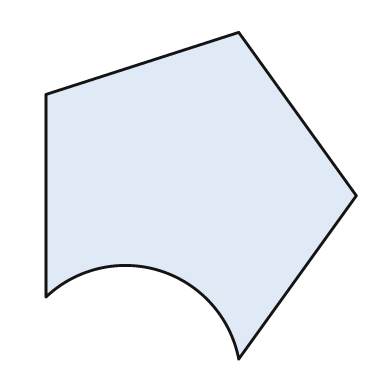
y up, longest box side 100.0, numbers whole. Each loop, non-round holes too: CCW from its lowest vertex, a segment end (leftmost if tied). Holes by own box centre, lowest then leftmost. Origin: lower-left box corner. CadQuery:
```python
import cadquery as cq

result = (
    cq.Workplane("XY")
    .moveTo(59.0, 0.0)
    .lineTo(95.0, 50.0)
    .lineTo(59.0, 100.0)
    .lineTo(0.0, 81.0)
    .lineTo(0.0, 19.0)
    .threePointArc((35.0, 27.0), (59.0, 0.0))
    .close()
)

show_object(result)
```